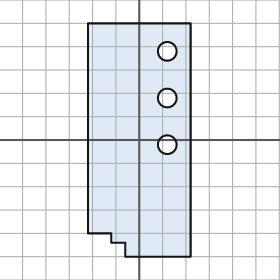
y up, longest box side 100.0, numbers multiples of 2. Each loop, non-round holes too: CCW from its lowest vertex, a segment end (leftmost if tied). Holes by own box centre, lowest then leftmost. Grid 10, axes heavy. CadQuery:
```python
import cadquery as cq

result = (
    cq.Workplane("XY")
    .moveTo(-6.0, -50.0)
    .lineTo(22.0, -50.0)
    .lineTo(22.0, 50.0)
    .lineTo(-22.0, 50.0)
    .lineTo(-22.0, -40.0)
    .lineTo(-12.0, -40.0)
    .lineTo(-12.0, -44.0)
    .lineTo(-6.0, -44.0)
    .close()
    .moveTo(12.0, -2.0)
    .circle(4.0)
    .moveTo(12.0, 18.0)
    .circle(4.0)
    .moveTo(12.0, 38.0)
    .circle(4.0)
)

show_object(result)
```